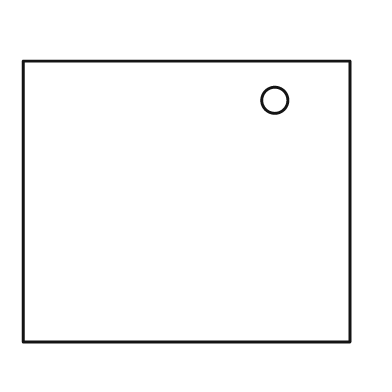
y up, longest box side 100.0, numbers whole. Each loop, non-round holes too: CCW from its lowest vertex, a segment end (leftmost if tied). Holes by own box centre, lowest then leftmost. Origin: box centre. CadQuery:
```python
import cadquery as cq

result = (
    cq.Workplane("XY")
    .moveTo(-50.0, -43.0)
    .lineTo(50.0, -43.0)
    .lineTo(50.0, 43.0)
    .lineTo(-50.0, 43.0)
    .close()
    .moveTo(27.0, 31.0)
    .circle(4.0)
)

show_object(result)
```